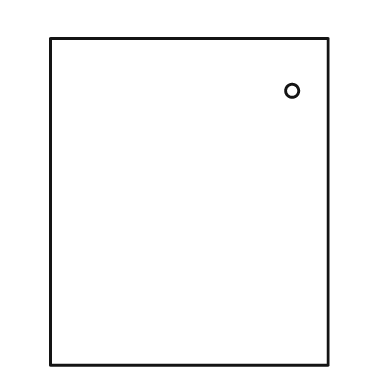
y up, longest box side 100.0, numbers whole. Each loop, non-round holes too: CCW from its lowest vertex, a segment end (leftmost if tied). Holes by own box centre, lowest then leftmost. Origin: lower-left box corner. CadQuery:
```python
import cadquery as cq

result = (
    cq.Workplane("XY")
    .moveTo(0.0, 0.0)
    .lineTo(85.0, 0.0)
    .lineTo(85.0, 100.0)
    .lineTo(0.0, 100.0)
    .close()
    .moveTo(74.0, 84.0)
    .circle(2.0)
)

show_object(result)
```